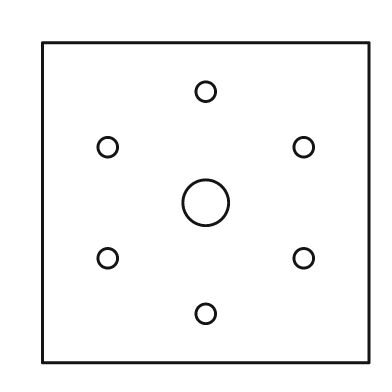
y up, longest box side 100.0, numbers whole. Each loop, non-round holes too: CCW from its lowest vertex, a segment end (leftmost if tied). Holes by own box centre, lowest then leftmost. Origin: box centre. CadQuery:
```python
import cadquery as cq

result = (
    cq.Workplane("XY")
    .moveTo(-50.0, -49.0)
    .lineTo(50.0, -49.0)
    .lineTo(50.0, 49.0)
    .lineTo(-50.0, 49.0)
    .close()
    .moveTo(0.0, -34.0)
    .circle(3.0)
    .moveTo(-30.0, -17.0)
    .circle(3.0)
    .moveTo(30.0, -17.0)
    .circle(3.0)
    .moveTo(0.0, 0.0)
    .circle(7.0)
    .moveTo(-30.0, 17.0)
    .circle(3.0)
    .moveTo(30.0, 17.0)
    .circle(3.0)
    .moveTo(0.0, 34.0)
    .circle(3.0)
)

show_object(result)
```